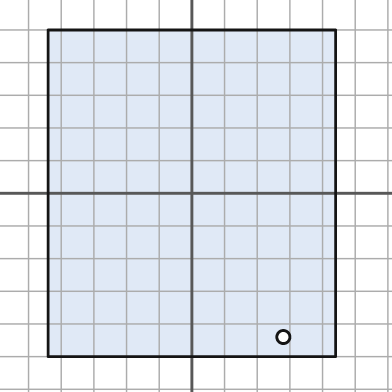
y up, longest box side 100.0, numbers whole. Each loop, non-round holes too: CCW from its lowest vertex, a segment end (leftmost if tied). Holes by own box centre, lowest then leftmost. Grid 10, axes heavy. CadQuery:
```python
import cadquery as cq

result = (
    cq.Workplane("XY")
    .moveTo(-44.0, -50.0)
    .lineTo(44.0, -50.0)
    .lineTo(44.0, 50.0)
    .lineTo(-44.0, 50.0)
    .close()
    .moveTo(28.0, -44.0)
    .circle(2.0)
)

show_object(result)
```